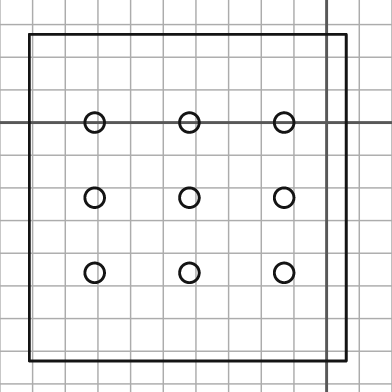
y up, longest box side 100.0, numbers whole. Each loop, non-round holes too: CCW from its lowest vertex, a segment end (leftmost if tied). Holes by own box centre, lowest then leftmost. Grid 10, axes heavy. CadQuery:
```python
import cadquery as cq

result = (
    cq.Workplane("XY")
    .moveTo(-91.0, -73.0)
    .lineTo(6.0, -73.0)
    .lineTo(6.0, 27.0)
    .lineTo(-91.0, 27.0)
    .close()
    .moveTo(-71.0, -46.0)
    .circle(3.0)
    .moveTo(-42.0, -46.0)
    .circle(3.0)
    .moveTo(-13.0, -46.0)
    .circle(3.0)
    .moveTo(-71.0, -23.0)
    .circle(3.0)
    .moveTo(-42.0, -23.0)
    .circle(3.0)
    .moveTo(-13.0, -23.0)
    .circle(3.0)
    .moveTo(-71.0, 0.0)
    .circle(3.0)
    .moveTo(-42.0, 0.0)
    .circle(3.0)
    .moveTo(-13.0, 0.0)
    .circle(3.0)
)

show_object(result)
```